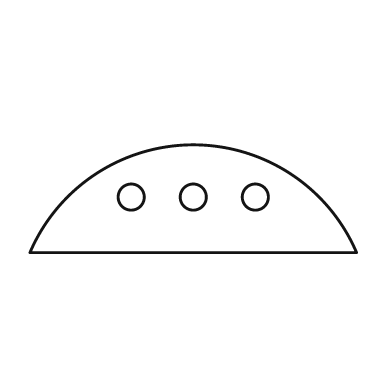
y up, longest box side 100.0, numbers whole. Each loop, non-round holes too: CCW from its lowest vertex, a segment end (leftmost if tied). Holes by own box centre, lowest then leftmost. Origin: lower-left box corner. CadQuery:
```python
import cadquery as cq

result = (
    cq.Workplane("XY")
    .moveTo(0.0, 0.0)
    .lineTo(100.0, 0.0)
    .threePointArc((50.0, 33.0), (0.0, 0.0))
    .close()
    .moveTo(31.0, 17.0)
    .circle(4.0)
    .moveTo(50.0, 17.0)
    .circle(4.0)
    .moveTo(69.0, 17.0)
    .circle(4.0)
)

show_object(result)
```